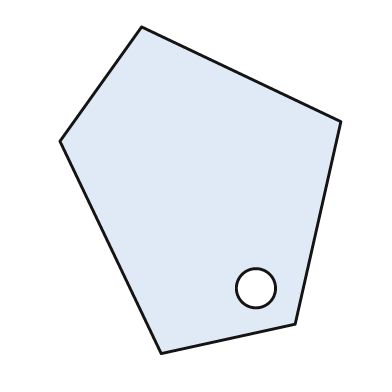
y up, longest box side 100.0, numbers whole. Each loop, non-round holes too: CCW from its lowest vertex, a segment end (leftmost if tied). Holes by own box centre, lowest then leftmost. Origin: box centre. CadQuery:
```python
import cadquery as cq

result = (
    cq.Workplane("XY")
    .moveTo(-12.0, -50.0)
    .lineTo(29.0, -41.0)
    .lineTo(43.0, 21.0)
    .lineTo(-18.0, 50.0)
    .lineTo(-43.0, 15.0)
    .close()
    .moveTo(17.0, -30.0)
    .circle(6.0)
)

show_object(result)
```